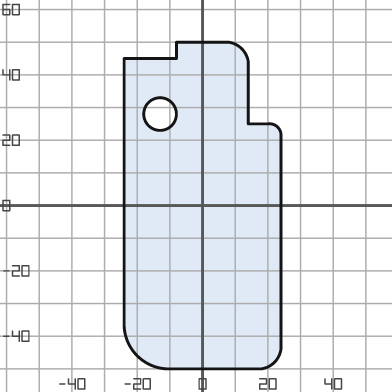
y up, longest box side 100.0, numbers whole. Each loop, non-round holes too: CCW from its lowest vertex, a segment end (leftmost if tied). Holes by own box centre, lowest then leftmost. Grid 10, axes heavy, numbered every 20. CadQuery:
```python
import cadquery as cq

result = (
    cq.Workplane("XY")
    .moveTo(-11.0, -50.0)
    .lineTo(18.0, -50.0)
    .threePointArc((22.0, -48.0), (24.0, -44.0))
    .lineTo(24.0, 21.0)
    .threePointArc((23.0, 24.0), (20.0, 25.0))
    .lineTo(14.0, 25.0)
    .lineTo(14.0, 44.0)
    .threePointArc((12.0, 48.0), (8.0, 50.0))
    .lineTo(-8.0, 50.0)
    .lineTo(-8.0, 45.0)
    .lineTo(-24.0, 45.0)
    .lineTo(-24.0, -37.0)
    .threePointArc((-20.0, -46.0), (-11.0, -50.0))
    .close()
    .moveTo(-13.0, 28.0)
    .circle(5.0)
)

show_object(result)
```